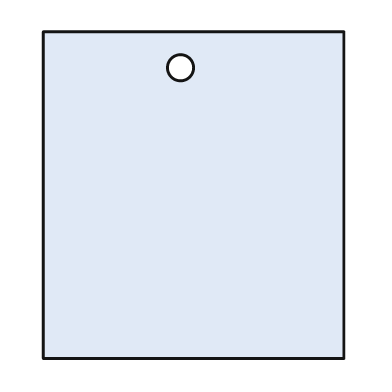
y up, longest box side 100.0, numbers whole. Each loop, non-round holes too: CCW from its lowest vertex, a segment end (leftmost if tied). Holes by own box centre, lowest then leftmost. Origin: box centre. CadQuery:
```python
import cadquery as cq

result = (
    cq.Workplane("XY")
    .moveTo(-46.0, -50.0)
    .lineTo(46.0, -50.0)
    .lineTo(46.0, 50.0)
    .lineTo(-46.0, 50.0)
    .close()
    .moveTo(-4.0, 39.0)
    .circle(4.0)
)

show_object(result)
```